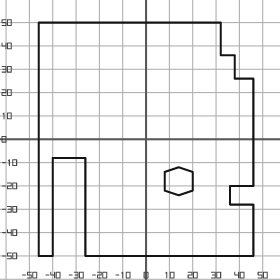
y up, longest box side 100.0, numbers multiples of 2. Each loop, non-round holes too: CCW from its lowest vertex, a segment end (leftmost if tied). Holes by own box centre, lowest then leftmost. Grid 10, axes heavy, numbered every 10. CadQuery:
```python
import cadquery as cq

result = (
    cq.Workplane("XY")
    .moveTo(-46.0, -50.0)
    .lineTo(-40.0, -50.0)
    .lineTo(-40.0, -8.0)
    .lineTo(-26.0, -8.0)
    .lineTo(-26.0, -50.0)
    .lineTo(46.0, -50.0)
    .lineTo(46.0, -28.0)
    .lineTo(36.0, -28.0)
    .lineTo(36.0, -20.0)
    .lineTo(46.0, -20.0)
    .lineTo(46.0, 26.0)
    .lineTo(38.0, 26.0)
    .lineTo(38.0, 36.0)
    .lineTo(32.0, 36.0)
    .lineTo(32.0, 50.0)
    .lineTo(-46.0, 50.0)
    .close()
    .moveTo(14.0, -24.0)
    .lineTo(20.0, -22.0)
    .lineTo(20.0, -14.0)
    .lineTo(14.0, -12.0)
    .lineTo(8.0, -14.0)
    .lineTo(8.0, -22.0)
    .close()
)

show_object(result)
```